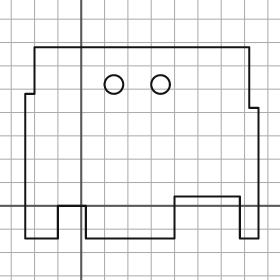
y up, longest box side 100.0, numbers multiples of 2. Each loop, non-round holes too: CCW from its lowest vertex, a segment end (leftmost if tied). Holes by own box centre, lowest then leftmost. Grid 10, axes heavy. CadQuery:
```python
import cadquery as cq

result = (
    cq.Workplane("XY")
    .moveTo(-24.0, -14.0)
    .lineTo(-10.0, -14.0)
    .lineTo(-10.0, 0.0)
    .lineTo(2.0, 0.0)
    .lineTo(2.0, -14.0)
    .lineTo(40.0, -14.0)
    .lineTo(40.0, 4.0)
    .lineTo(68.0, 4.0)
    .lineTo(68.0, -14.0)
    .lineTo(76.0, -14.0)
    .lineTo(76.0, 42.0)
    .lineTo(72.0, 42.0)
    .lineTo(72.0, 68.0)
    .lineTo(-20.0, 68.0)
    .lineTo(-20.0, 48.0)
    .lineTo(-24.0, 48.0)
    .close()
    .moveTo(14.0, 52.0)
    .circle(4.0)
    .moveTo(34.0, 52.0)
    .circle(4.0)
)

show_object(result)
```